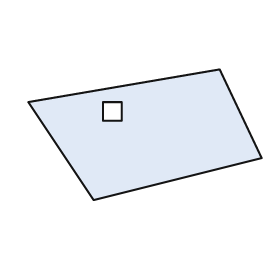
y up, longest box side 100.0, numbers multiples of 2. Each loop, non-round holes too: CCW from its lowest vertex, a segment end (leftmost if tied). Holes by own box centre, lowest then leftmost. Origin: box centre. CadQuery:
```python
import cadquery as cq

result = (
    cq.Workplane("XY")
    .moveTo(-22.0, -28.0)
    .lineTo(50.0, -10.0)
    .lineTo(32.0, 28.0)
    .lineTo(-50.0, 14.0)
    .close()
    .moveTo(-18.0, 6.0)
    .lineTo(-10.0, 6.0)
    .lineTo(-10.0, 14.0)
    .lineTo(-18.0, 14.0)
    .close()
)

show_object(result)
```